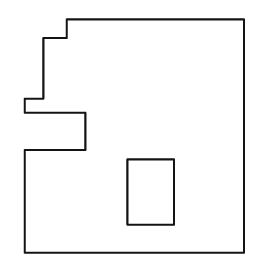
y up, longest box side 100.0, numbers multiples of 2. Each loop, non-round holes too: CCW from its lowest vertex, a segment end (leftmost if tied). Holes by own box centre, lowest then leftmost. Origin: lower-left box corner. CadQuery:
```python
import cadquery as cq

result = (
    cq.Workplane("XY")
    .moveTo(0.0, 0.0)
    .lineTo(94.0, 0.0)
    .lineTo(94.0, 100.0)
    .lineTo(18.0, 100.0)
    .lineTo(18.0, 92.0)
    .lineTo(8.0, 92.0)
    .lineTo(8.0, 66.0)
    .lineTo(0.0, 66.0)
    .lineTo(0.0, 60.0)
    .lineTo(26.0, 60.0)
    .lineTo(26.0, 44.0)
    .lineTo(0.0, 44.0)
    .close()
    .moveTo(44.0, 12.0)
    .lineTo(64.0, 12.0)
    .lineTo(64.0, 40.0)
    .lineTo(44.0, 40.0)
    .close()
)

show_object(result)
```